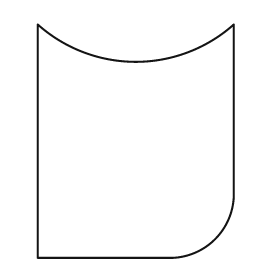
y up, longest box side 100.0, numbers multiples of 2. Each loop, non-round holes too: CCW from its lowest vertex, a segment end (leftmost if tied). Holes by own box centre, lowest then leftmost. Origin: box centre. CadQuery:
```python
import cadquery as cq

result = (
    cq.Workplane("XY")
    .moveTo(-42.0, -50.0)
    .lineTo(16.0, -50.0)
    .threePointArc((34.0, -42.0), (42.0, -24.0))
    .lineTo(42.0, 50.0)
    .threePointArc((0.0, 34.0), (-42.0, 50.0))
    .close()
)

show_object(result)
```